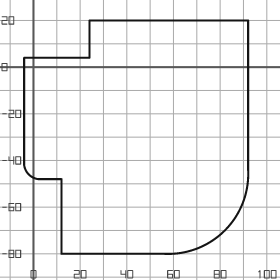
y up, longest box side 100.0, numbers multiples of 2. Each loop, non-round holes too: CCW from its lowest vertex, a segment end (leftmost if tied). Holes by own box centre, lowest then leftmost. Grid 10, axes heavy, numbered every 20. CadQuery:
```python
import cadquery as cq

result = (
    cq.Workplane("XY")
    .moveTo(12.0, -80.0)
    .lineTo(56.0, -80.0)
    .threePointArc((82.0, -70.0), (92.0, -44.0))
    .lineTo(92.0, 20.0)
    .lineTo(24.0, 20.0)
    .lineTo(24.0, 4.0)
    .lineTo(-4.0, 4.0)
    .lineTo(-4.0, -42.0)
    .threePointArc((-2.0, -46.0), (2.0, -48.0))
    .lineTo(12.0, -48.0)
    .close()
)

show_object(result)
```